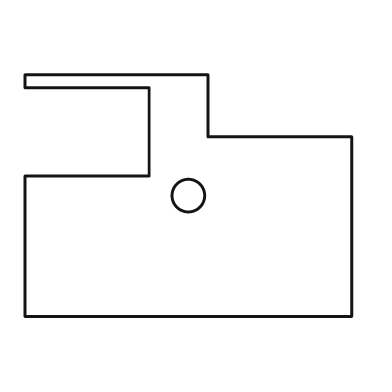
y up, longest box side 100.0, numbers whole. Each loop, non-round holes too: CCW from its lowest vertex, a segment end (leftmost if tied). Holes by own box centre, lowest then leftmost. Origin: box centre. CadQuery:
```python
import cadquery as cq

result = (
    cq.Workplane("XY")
    .moveTo(-50.0, -37.0)
    .lineTo(50.0, -37.0)
    .lineTo(50.0, 18.0)
    .lineTo(6.0, 18.0)
    .lineTo(6.0, 37.0)
    .lineTo(-50.0, 37.0)
    .lineTo(-50.0, 33.0)
    .lineTo(-12.0, 33.0)
    .lineTo(-12.0, 6.0)
    .lineTo(-50.0, 6.0)
    .close()
    .moveTo(0.0, 0.0)
    .circle(5.0)
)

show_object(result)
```